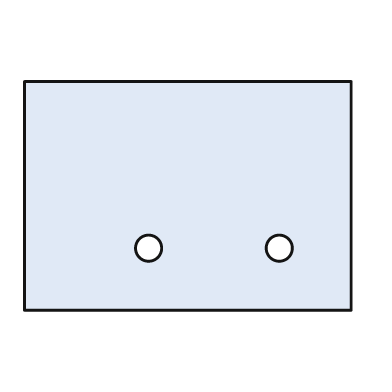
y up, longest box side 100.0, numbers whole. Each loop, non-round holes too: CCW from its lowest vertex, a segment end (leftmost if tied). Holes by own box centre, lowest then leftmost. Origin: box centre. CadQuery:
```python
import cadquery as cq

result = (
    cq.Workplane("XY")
    .moveTo(-50.0, -35.0)
    .lineTo(50.0, -35.0)
    .lineTo(50.0, 35.0)
    .lineTo(-50.0, 35.0)
    .close()
    .moveTo(-12.0, -16.0)
    .circle(4.0)
    .moveTo(28.0, -16.0)
    .circle(4.0)
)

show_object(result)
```